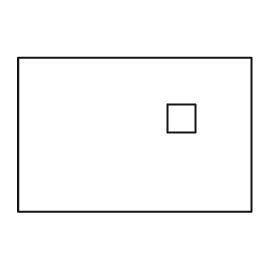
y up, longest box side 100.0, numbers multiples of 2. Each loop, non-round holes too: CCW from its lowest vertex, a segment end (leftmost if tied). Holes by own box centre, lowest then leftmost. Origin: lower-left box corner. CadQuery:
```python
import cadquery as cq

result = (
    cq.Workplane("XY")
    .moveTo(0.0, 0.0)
    .lineTo(100.0, 0.0)
    .lineTo(100.0, 66.0)
    .lineTo(0.0, 66.0)
    .close()
    .moveTo(64.0, 34.0)
    .lineTo(76.0, 34.0)
    .lineTo(76.0, 46.0)
    .lineTo(64.0, 46.0)
    .close()
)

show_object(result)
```